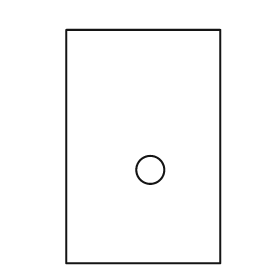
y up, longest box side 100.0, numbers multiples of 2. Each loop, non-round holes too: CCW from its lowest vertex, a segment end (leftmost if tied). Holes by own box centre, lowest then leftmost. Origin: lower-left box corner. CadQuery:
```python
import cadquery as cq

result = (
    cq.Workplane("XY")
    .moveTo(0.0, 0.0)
    .lineTo(66.0, 0.0)
    .lineTo(66.0, 100.0)
    .lineTo(0.0, 100.0)
    .close()
    .moveTo(36.0, 40.0)
    .circle(6.0)
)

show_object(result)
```